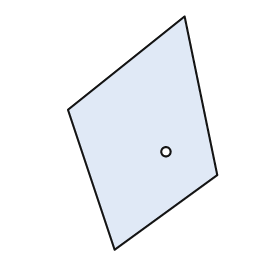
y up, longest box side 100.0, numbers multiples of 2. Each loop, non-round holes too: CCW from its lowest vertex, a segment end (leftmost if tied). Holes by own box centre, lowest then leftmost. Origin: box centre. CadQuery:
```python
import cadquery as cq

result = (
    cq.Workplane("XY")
    .moveTo(-12.0, -50.0)
    .lineTo(32.0, -18.0)
    .lineTo(18.0, 50.0)
    .lineTo(-32.0, 10.0)
    .close()
    .moveTo(10.0, -8.0)
    .circle(2.0)
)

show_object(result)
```